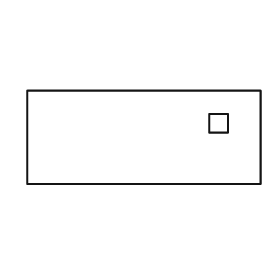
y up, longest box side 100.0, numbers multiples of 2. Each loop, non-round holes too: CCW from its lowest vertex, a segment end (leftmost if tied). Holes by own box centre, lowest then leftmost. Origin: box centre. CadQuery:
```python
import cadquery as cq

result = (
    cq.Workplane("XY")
    .moveTo(-50.0, -20.0)
    .lineTo(50.0, -20.0)
    .lineTo(50.0, 20.0)
    .lineTo(-50.0, 20.0)
    .close()
    .moveTo(28.0, 2.0)
    .lineTo(36.0, 2.0)
    .lineTo(36.0, 10.0)
    .lineTo(28.0, 10.0)
    .close()
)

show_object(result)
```